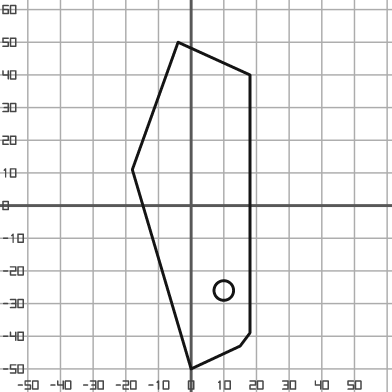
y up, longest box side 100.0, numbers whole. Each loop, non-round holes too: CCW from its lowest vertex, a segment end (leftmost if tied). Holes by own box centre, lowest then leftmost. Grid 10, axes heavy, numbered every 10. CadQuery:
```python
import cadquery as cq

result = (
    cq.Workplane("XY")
    .moveTo(0.0, -50.0)
    .lineTo(15.0, -43.0)
    .lineTo(18.0, -39.0)
    .lineTo(18.0, 40.0)
    .lineTo(-4.0, 50.0)
    .lineTo(-18.0, 11.0)
    .close()
    .moveTo(10.0, -26.0)
    .circle(3.0)
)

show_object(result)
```